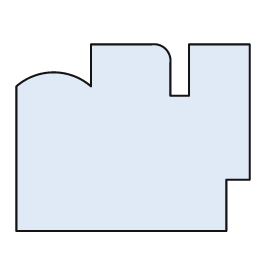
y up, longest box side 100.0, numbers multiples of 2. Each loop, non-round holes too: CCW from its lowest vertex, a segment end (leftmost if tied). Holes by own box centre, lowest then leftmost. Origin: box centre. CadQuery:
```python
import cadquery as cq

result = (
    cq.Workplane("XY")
    .moveTo(-50.0, -40.0)
    .lineTo(40.0, -40.0)
    .lineTo(40.0, -18.0)
    .lineTo(50.0, -18.0)
    .lineTo(50.0, 40.0)
    .lineTo(24.0, 40.0)
    .lineTo(24.0, 18.0)
    .lineTo(16.0, 18.0)
    .lineTo(16.0, 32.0)
    .threePointArc((14.0, 38.0), (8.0, 40.0))
    .lineTo(-18.0, 40.0)
    .lineTo(-18.0, 22.0)
    .threePointArc((-34.0, 28.0), (-50.0, 22.0))
    .close()
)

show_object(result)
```